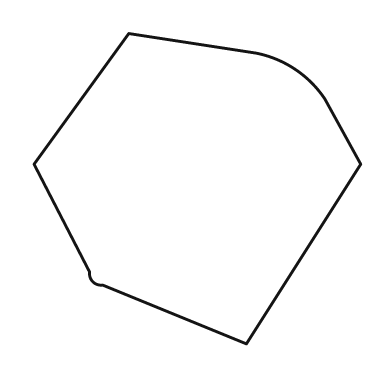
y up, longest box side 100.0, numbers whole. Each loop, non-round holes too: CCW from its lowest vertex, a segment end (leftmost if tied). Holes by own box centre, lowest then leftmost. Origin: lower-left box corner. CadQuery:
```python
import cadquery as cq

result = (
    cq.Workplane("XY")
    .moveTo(65.0, 0.0)
    .lineTo(100.0, 55.0)
    .lineTo(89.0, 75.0)
    .threePointArc((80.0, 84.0), (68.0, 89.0))
    .lineTo(29.0, 95.0)
    .lineTo(0.0, 55.0)
    .lineTo(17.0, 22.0)
    .threePointArc((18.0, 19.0), (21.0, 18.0))
    .close()
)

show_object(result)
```